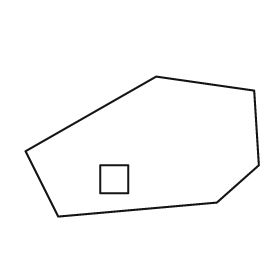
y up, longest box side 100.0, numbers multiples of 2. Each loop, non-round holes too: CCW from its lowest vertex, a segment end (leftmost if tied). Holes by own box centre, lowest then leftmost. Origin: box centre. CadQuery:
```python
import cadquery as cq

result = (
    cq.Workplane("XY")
    .moveTo(-36.0, -30.0)
    .lineTo(32.0, -24.0)
    .lineTo(50.0, -8.0)
    .lineTo(48.0, 24.0)
    .lineTo(6.0, 30.0)
    .lineTo(-50.0, -2.0)
    .close()
    .moveTo(-18.0, -20.0)
    .lineTo(-6.0, -20.0)
    .lineTo(-6.0, -8.0)
    .lineTo(-18.0, -8.0)
    .close()
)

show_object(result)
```